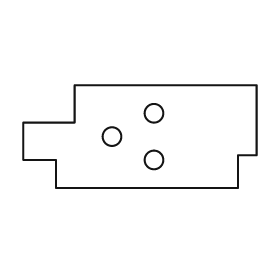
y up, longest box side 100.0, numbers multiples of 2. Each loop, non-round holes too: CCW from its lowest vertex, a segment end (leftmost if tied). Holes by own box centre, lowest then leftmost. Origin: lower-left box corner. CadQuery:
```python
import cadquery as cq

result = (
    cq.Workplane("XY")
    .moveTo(14.0, 0.0)
    .lineTo(92.0, 0.0)
    .lineTo(92.0, 14.0)
    .lineTo(100.0, 14.0)
    .lineTo(100.0, 44.0)
    .lineTo(22.0, 44.0)
    .lineTo(22.0, 28.0)
    .lineTo(0.0, 28.0)
    .lineTo(0.0, 12.0)
    .lineTo(14.0, 12.0)
    .close()
    .moveTo(56.0, 12.0)
    .circle(4.0)
    .moveTo(38.0, 22.0)
    .circle(4.0)
    .moveTo(56.0, 32.0)
    .circle(4.0)
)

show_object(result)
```